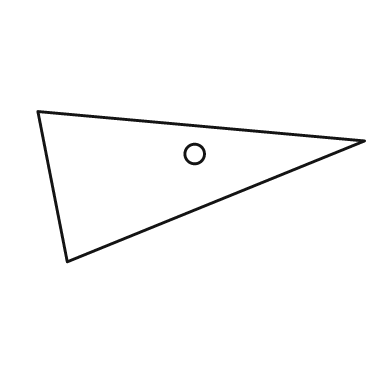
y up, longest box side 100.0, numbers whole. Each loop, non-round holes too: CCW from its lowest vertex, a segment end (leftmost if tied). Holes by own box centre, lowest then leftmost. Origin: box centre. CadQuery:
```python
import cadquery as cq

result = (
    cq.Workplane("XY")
    .moveTo(-41.0, -23.0)
    .lineTo(50.0, 14.0)
    .lineTo(-50.0, 23.0)
    .close()
    .moveTo(-2.0, 10.0)
    .circle(3.0)
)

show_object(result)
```